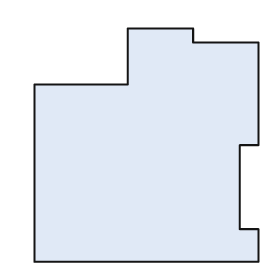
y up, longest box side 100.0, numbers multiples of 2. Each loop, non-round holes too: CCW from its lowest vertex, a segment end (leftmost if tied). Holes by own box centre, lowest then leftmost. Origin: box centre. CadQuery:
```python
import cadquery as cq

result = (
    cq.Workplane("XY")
    .moveTo(-48.0, -50.0)
    .lineTo(48.0, -50.0)
    .lineTo(48.0, -36.0)
    .lineTo(40.0, -36.0)
    .lineTo(40.0, 0.0)
    .lineTo(48.0, 0.0)
    .lineTo(48.0, 44.0)
    .lineTo(20.0, 44.0)
    .lineTo(20.0, 50.0)
    .lineTo(-8.0, 50.0)
    .lineTo(-8.0, 26.0)
    .lineTo(-48.0, 26.0)
    .close()
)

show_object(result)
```